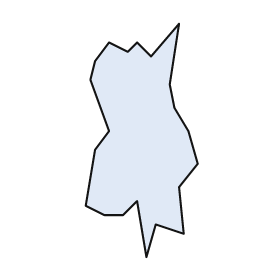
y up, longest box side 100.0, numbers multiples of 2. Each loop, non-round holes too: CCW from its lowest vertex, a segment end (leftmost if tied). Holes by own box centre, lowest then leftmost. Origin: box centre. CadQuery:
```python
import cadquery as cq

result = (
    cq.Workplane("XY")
    .moveTo(2.0, -50.0)
    .lineTo(6.0, -36.0)
    .lineTo(18.0, -40.0)
    .lineTo(16.0, -20.0)
    .lineTo(24.0, -10.0)
    .lineTo(20.0, 4.0)
    .lineTo(14.0, 14.0)
    .lineTo(12.0, 24.0)
    .lineTo(16.0, 50.0)
    .lineTo(4.0, 36.0)
    .lineTo(-2.0, 42.0)
    .lineTo(-6.0, 38.0)
    .lineTo(-14.0, 42.0)
    .lineTo(-20.0, 34.0)
    .lineTo(-22.0, 26.0)
    .lineTo(-14.0, 4.0)
    .lineTo(-20.0, -4.0)
    .lineTo(-24.0, -28.0)
    .lineTo(-16.0, -32.0)
    .lineTo(-8.0, -32.0)
    .lineTo(-2.0, -26.0)
    .close()
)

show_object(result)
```